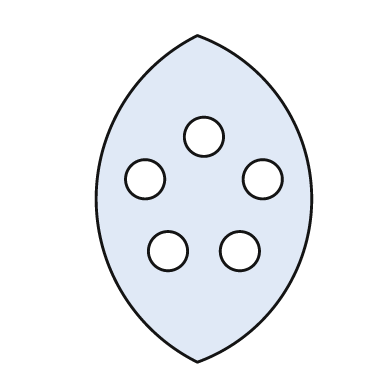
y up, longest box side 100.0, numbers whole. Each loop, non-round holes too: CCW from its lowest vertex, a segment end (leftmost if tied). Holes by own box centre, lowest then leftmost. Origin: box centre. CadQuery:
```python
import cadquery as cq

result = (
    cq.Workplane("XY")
    .moveTo(-2.0, -50.0)
    .threePointArc((33.0, 0.0), (-2.0, 50.0))
    .threePointArc((-33.0, 0.0), (-2.0, -50.0))
    .close()
    .moveTo(-11.0, -16.0)
    .circle(6.0)
    .moveTo(11.0, -16.0)
    .circle(6.0)
    .moveTo(-18.0, 6.0)
    .circle(6.0)
    .moveTo(18.0, 6.0)
    .circle(6.0)
    .moveTo(0.0, 19.0)
    .circle(6.0)
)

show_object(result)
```